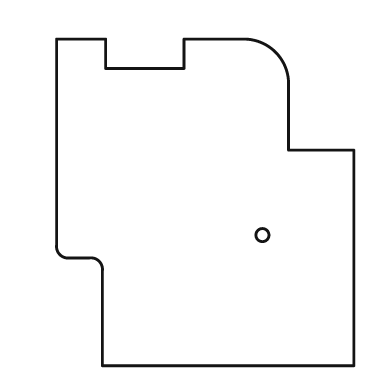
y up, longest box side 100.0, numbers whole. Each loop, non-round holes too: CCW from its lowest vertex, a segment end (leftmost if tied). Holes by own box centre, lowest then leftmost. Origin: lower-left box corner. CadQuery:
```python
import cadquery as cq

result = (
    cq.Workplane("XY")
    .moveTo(14.0, 0.0)
    .lineTo(91.0, 0.0)
    .lineTo(91.0, 66.0)
    .lineTo(71.0, 66.0)
    .lineTo(71.0, 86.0)
    .threePointArc((67.0, 96.0), (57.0, 100.0))
    .lineTo(39.0, 100.0)
    .lineTo(39.0, 91.0)
    .lineTo(15.0, 91.0)
    .lineTo(15.0, 100.0)
    .lineTo(0.0, 100.0)
    .lineTo(0.0, 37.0)
    .threePointArc((1.0, 34.0), (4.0, 33.0))
    .lineTo(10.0, 33.0)
    .threePointArc((13.0, 32.0), (14.0, 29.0))
    .close()
    .moveTo(63.0, 40.0)
    .circle(2.0)
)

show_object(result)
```